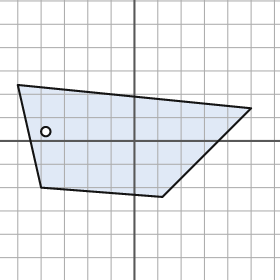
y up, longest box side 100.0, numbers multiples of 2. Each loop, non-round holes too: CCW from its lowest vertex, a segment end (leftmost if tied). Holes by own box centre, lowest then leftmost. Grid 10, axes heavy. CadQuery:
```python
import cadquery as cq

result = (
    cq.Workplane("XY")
    .moveTo(12.0, -24.0)
    .lineTo(50.0, 14.0)
    .lineTo(-50.0, 24.0)
    .lineTo(-40.0, -20.0)
    .close()
    .moveTo(-38.0, 4.0)
    .circle(2.0)
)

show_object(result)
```